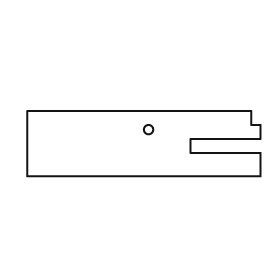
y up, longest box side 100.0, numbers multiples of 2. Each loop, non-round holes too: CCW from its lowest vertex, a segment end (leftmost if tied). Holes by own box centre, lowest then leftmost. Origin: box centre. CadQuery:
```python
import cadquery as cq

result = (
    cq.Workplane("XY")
    .moveTo(-50.0, -14.0)
    .lineTo(50.0, -14.0)
    .lineTo(50.0, -4.0)
    .lineTo(20.0, -4.0)
    .lineTo(20.0, 2.0)
    .lineTo(50.0, 2.0)
    .lineTo(50.0, 8.0)
    .lineTo(46.0, 8.0)
    .lineTo(46.0, 14.0)
    .lineTo(-50.0, 14.0)
    .close()
    .moveTo(2.0, 6.0)
    .circle(2.0)
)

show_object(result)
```